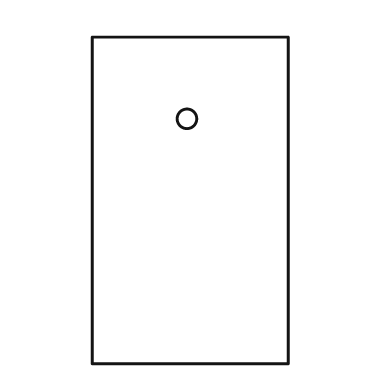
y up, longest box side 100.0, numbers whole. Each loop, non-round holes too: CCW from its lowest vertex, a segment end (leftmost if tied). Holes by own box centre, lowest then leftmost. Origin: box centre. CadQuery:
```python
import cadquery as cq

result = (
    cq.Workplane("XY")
    .moveTo(-30.0, -50.0)
    .lineTo(30.0, -50.0)
    .lineTo(30.0, 50.0)
    .lineTo(-30.0, 50.0)
    .close()
    .moveTo(-1.0, 25.0)
    .circle(3.0)
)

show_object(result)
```